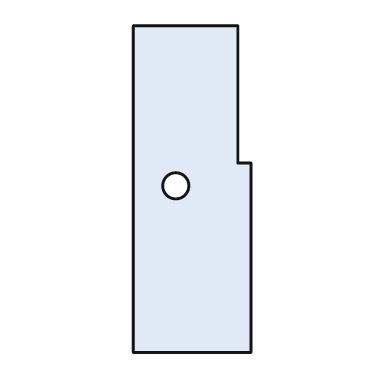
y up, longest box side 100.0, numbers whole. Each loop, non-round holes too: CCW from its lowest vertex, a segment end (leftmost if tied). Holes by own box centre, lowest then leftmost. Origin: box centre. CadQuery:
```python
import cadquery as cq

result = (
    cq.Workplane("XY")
    .moveTo(-18.0, -50.0)
    .lineTo(18.0, -50.0)
    .lineTo(18.0, 8.0)
    .lineTo(14.0, 8.0)
    .lineTo(14.0, 50.0)
    .lineTo(-18.0, 50.0)
    .close()
    .moveTo(-5.0, 1.0)
    .circle(4.0)
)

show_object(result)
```